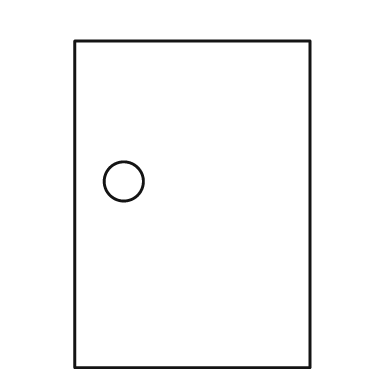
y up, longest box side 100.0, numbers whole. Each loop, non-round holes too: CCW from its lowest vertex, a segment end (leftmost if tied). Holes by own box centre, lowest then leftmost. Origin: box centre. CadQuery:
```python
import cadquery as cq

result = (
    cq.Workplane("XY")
    .moveTo(-36.0, -50.0)
    .lineTo(36.0, -50.0)
    .lineTo(36.0, 50.0)
    .lineTo(-36.0, 50.0)
    .close()
    .moveTo(-21.0, 7.0)
    .circle(6.0)
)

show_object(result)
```